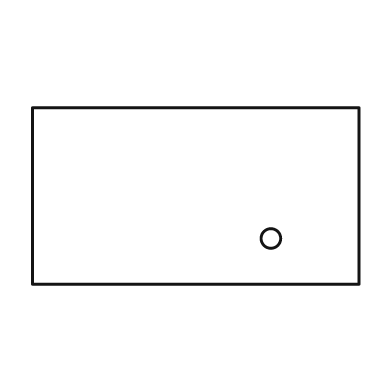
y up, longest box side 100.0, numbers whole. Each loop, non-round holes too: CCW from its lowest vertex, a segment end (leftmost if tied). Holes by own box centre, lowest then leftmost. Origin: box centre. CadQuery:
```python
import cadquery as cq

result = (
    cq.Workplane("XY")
    .moveTo(-50.0, -27.0)
    .lineTo(50.0, -27.0)
    .lineTo(50.0, 27.0)
    .lineTo(-50.0, 27.0)
    .close()
    .moveTo(23.0, -13.0)
    .circle(3.0)
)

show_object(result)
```